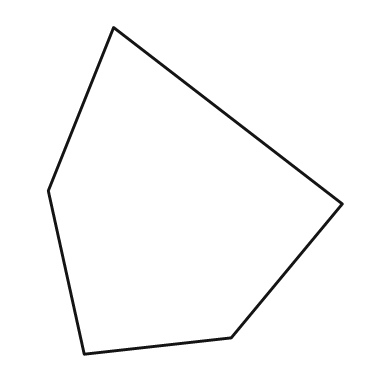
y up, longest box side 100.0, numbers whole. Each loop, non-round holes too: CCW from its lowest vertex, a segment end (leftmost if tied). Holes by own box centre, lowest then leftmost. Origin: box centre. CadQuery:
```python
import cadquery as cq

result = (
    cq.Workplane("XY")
    .moveTo(-34.0, -50.0)
    .lineTo(11.0, -45.0)
    .lineTo(45.0, -4.0)
    .lineTo(-25.0, 50.0)
    .lineTo(-45.0, 0.0)
    .close()
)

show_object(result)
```